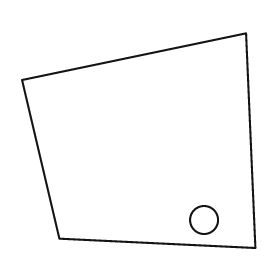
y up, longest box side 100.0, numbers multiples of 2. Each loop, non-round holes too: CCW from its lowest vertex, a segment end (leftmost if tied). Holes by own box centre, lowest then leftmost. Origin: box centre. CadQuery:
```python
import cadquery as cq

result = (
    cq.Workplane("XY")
    .moveTo(50.0, -46.0)
    .lineTo(46.0, 46.0)
    .lineTo(-50.0, 26.0)
    .lineTo(-34.0, -42.0)
    .close()
    .moveTo(28.0, -34.0)
    .circle(6.0)
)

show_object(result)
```